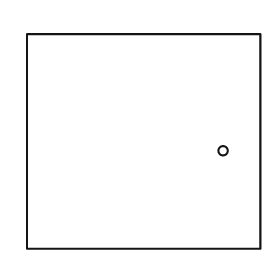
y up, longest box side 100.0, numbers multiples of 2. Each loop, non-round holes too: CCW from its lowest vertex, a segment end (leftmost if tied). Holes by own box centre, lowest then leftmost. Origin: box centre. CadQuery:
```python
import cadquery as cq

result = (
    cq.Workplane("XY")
    .moveTo(-50.0, -46.0)
    .lineTo(50.0, -46.0)
    .lineTo(50.0, 46.0)
    .lineTo(-50.0, 46.0)
    .close()
    .moveTo(34.0, -4.0)
    .circle(2.0)
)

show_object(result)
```